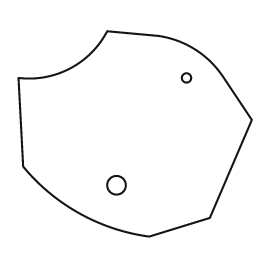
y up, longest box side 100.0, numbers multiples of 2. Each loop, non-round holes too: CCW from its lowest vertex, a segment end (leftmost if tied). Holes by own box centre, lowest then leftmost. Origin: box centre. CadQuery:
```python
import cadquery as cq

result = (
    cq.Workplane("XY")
    .moveTo(6.0, -44.0)
    .lineTo(32.0, -36.0)
    .lineTo(50.0, 6.0)
    .lineTo(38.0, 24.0)
    .threePointArc((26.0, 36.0), (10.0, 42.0))
    .lineTo(-12.0, 44.0)
    .threePointArc((-28.0, 28.0), (-50.0, 24.0))
    .lineTo(-48.0, -14.0)
    .threePointArc((-24.0, -34.0), (6.0, -44.0))
    .close()
    .moveTo(-8.0, -22.0)
    .circle(4.0)
    .moveTo(22.0, 24.0)
    .circle(2.0)
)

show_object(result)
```